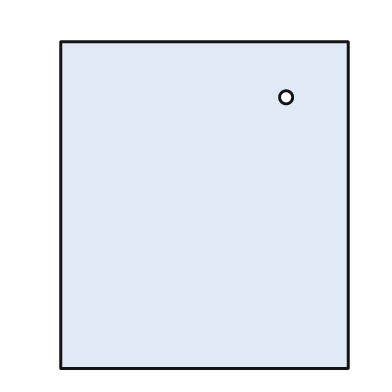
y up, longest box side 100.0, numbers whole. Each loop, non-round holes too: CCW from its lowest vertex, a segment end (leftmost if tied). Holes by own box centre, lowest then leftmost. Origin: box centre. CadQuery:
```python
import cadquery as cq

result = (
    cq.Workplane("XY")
    .moveTo(-44.0, -50.0)
    .lineTo(44.0, -50.0)
    .lineTo(44.0, 50.0)
    .lineTo(-44.0, 50.0)
    .close()
    .moveTo(25.0, 33.0)
    .circle(2.0)
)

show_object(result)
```